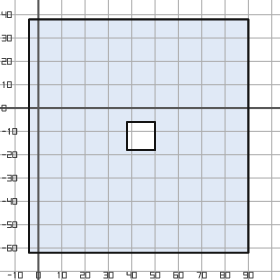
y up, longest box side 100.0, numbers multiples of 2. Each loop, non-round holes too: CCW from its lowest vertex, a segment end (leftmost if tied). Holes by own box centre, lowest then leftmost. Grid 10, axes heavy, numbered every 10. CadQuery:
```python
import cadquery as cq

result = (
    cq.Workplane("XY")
    .moveTo(-4.0, -62.0)
    .lineTo(90.0, -62.0)
    .lineTo(90.0, 38.0)
    .lineTo(-4.0, 38.0)
    .close()
    .moveTo(38.0, -18.0)
    .lineTo(50.0, -18.0)
    .lineTo(50.0, -6.0)
    .lineTo(38.0, -6.0)
    .close()
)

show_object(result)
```